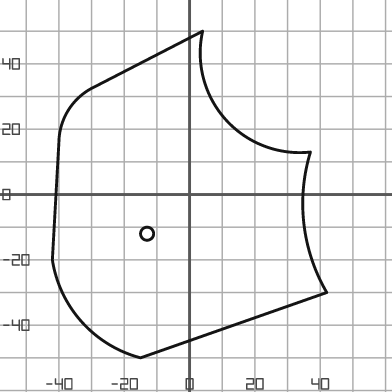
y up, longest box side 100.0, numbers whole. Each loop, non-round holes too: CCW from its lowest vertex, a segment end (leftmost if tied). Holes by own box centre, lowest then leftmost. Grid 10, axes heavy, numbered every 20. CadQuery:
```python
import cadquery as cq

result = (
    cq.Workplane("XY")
    .moveTo(-15.0, -50.0)
    .lineTo(42.0, -30.0)
    .threePointArc((35.0, -9.0), (37.0, 13.0))
    .threePointArc((11.0, 23.0), (4.0, 50.0))
    .lineTo(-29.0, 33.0)
    .threePointArc((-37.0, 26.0), (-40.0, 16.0))
    .lineTo(-42.0, -20.0)
    .threePointArc((-33.0, -39.0), (-15.0, -50.0))
    .close()
    .moveTo(-13.0, -12.0)
    .circle(2.0)
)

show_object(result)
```